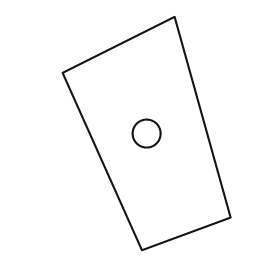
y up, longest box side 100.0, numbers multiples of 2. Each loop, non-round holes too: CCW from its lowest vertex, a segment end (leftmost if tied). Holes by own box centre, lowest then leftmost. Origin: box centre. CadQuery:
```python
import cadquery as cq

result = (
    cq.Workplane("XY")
    .moveTo(-2.0, -50.0)
    .lineTo(36.0, -36.0)
    .lineTo(12.0, 50.0)
    .lineTo(-36.0, 26.0)
    .close()
    .moveTo(0.0, 0.0)
    .circle(6.0)
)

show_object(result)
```